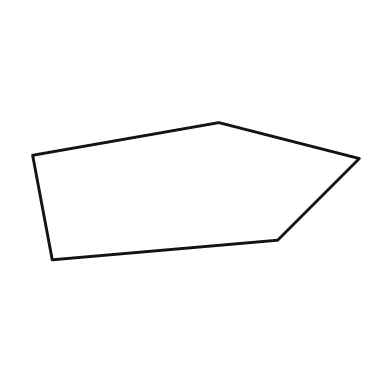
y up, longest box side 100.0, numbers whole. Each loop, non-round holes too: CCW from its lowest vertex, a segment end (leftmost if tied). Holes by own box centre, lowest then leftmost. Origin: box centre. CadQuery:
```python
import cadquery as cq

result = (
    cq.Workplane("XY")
    .moveTo(-44.0, -21.0)
    .lineTo(25.0, -15.0)
    .lineTo(50.0, 10.0)
    .lineTo(7.0, 21.0)
    .lineTo(-50.0, 11.0)
    .close()
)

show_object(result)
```